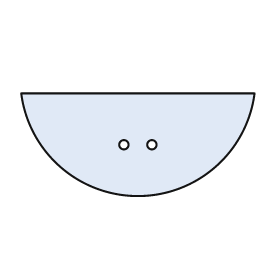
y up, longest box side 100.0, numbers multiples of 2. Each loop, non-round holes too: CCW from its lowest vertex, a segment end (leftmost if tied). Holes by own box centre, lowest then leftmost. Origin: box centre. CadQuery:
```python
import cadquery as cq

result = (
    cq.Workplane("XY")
    .moveTo(-50.0, 22.0)
    .threePointArc((0.0, -22.0), (50.0, 22.0))
    .close()
    .moveTo(-6.0, 0.0)
    .circle(2.0)
    .moveTo(6.0, 0.0)
    .circle(2.0)
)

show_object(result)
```